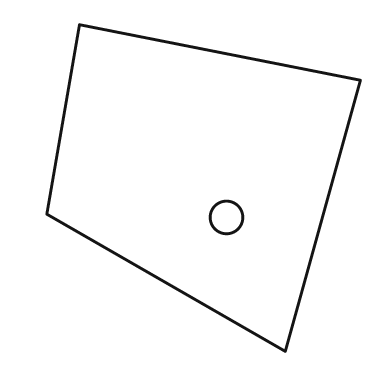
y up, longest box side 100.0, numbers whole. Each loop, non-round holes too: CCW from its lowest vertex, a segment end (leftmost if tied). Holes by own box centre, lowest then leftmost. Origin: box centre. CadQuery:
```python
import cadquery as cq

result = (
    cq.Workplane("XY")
    .moveTo(25.0, -50.0)
    .lineTo(48.0, 33.0)
    .lineTo(-38.0, 50.0)
    .lineTo(-48.0, -8.0)
    .close()
    .moveTo(7.0, -9.0)
    .circle(5.0)
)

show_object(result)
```